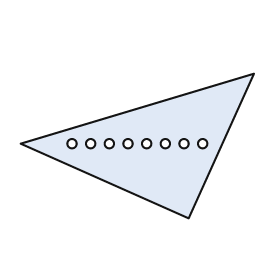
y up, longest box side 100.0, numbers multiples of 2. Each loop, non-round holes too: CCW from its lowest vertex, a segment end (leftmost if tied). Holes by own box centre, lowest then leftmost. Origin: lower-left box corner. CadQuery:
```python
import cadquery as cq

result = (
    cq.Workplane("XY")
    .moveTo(72.0, 0.0)
    .lineTo(100.0, 62.0)
    .lineTo(0.0, 32.0)
    .close()
    .moveTo(22.0, 32.0)
    .circle(2.0)
    .moveTo(30.0, 32.0)
    .circle(2.0)
    .moveTo(38.0, 32.0)
    .circle(2.0)
    .moveTo(46.0, 32.0)
    .circle(2.0)
    .moveTo(54.0, 32.0)
    .circle(2.0)
    .moveTo(62.0, 32.0)
    .circle(2.0)
    .moveTo(70.0, 32.0)
    .circle(2.0)
    .moveTo(78.0, 32.0)
    .circle(2.0)
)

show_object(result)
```